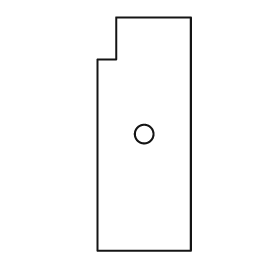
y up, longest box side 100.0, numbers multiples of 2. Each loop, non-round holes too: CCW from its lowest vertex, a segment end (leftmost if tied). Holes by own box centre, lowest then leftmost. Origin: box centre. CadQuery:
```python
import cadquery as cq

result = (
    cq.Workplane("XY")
    .moveTo(-20.0, -50.0)
    .lineTo(20.0, -50.0)
    .lineTo(20.0, 50.0)
    .lineTo(-12.0, 50.0)
    .lineTo(-12.0, 32.0)
    .lineTo(-20.0, 32.0)
    .close()
    .moveTo(0.0, 0.0)
    .circle(4.0)
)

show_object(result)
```